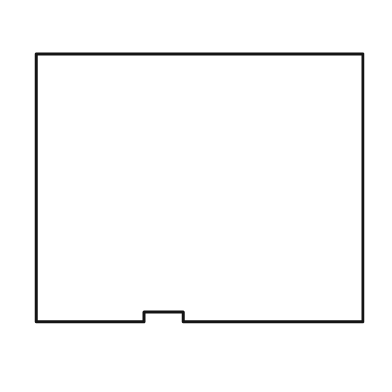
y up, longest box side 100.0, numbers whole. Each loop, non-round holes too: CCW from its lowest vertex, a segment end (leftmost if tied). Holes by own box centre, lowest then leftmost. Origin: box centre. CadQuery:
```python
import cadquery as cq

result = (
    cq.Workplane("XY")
    .moveTo(-50.0, -41.0)
    .lineTo(-17.0, -41.0)
    .lineTo(-17.0, -38.0)
    .lineTo(-5.0, -38.0)
    .lineTo(-5.0, -41.0)
    .lineTo(50.0, -41.0)
    .lineTo(50.0, 41.0)
    .lineTo(-50.0, 41.0)
    .close()
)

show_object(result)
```